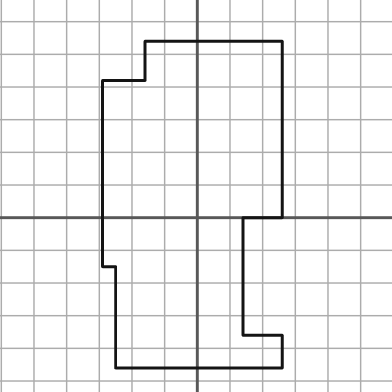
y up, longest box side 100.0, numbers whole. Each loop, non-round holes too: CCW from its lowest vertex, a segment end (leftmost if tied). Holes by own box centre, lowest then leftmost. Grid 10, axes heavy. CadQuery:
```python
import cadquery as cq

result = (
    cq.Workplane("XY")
    .moveTo(-25.0, -46.0)
    .lineTo(26.0, -46.0)
    .lineTo(26.0, -36.0)
    .lineTo(14.0, -36.0)
    .lineTo(14.0, 0.0)
    .lineTo(26.0, 0.0)
    .lineTo(26.0, 54.0)
    .lineTo(-16.0, 54.0)
    .lineTo(-16.0, 42.0)
    .lineTo(-29.0, 42.0)
    .lineTo(-29.0, -15.0)
    .lineTo(-25.0, -15.0)
    .close()
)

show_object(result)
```